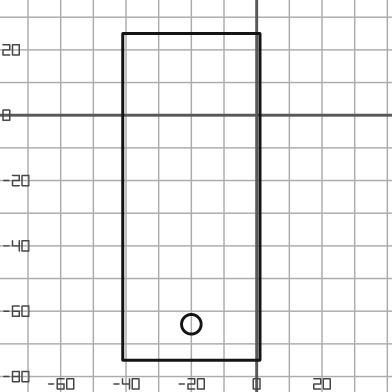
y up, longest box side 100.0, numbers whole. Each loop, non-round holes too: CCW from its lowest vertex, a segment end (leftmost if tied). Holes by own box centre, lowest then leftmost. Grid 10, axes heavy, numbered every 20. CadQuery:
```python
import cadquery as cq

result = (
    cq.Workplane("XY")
    .moveTo(-41.0, -75.0)
    .lineTo(1.0, -75.0)
    .lineTo(1.0, 25.0)
    .lineTo(-41.0, 25.0)
    .close()
    .moveTo(-20.0, -64.0)
    .circle(3.0)
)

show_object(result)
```